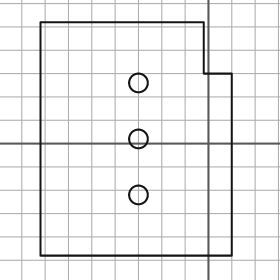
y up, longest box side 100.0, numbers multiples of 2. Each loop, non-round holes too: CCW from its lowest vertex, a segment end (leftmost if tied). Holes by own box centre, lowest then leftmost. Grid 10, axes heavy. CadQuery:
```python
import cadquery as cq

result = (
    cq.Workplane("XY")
    .moveTo(-72.0, -48.0)
    .lineTo(10.0, -48.0)
    .lineTo(10.0, 30.0)
    .lineTo(-2.0, 30.0)
    .lineTo(-2.0, 52.0)
    .lineTo(-72.0, 52.0)
    .close()
    .moveTo(-30.0, -22.0)
    .circle(4.0)
    .moveTo(-30.0, 2.0)
    .circle(4.0)
    .moveTo(-30.0, 26.0)
    .circle(4.0)
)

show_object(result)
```